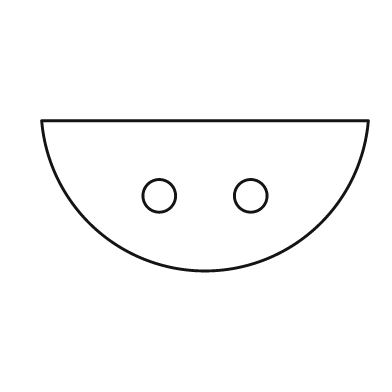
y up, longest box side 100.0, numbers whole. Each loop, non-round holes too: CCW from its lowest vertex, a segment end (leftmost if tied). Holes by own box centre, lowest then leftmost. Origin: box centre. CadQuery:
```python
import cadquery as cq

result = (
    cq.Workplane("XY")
    .moveTo(-50.0, 23.0)
    .threePointArc((0.0, -23.0), (50.0, 23.0))
    .close()
    .moveTo(-14.0, 0.0)
    .circle(5.0)
    .moveTo(14.0, 0.0)
    .circle(5.0)
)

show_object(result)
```